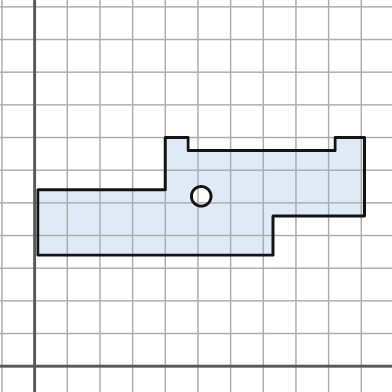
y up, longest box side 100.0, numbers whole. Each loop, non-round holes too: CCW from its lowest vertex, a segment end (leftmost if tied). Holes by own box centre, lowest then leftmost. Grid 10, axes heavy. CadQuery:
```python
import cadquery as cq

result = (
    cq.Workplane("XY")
    .moveTo(1.0, 34.0)
    .lineTo(73.0, 34.0)
    .lineTo(73.0, 46.0)
    .lineTo(101.0, 46.0)
    .lineTo(101.0, 70.0)
    .lineTo(92.0, 70.0)
    .lineTo(92.0, 66.0)
    .lineTo(47.0, 66.0)
    .lineTo(47.0, 70.0)
    .lineTo(40.0, 70.0)
    .lineTo(40.0, 54.0)
    .lineTo(1.0, 54.0)
    .close()
    .moveTo(51.0, 52.0)
    .circle(3.0)
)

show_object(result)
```